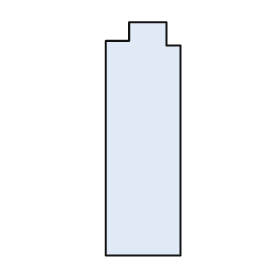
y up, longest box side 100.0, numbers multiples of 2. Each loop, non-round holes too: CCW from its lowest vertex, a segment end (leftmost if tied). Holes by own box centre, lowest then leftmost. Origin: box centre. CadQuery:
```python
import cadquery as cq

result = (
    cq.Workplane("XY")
    .moveTo(-16.0, -50.0)
    .lineTo(16.0, -50.0)
    .lineTo(16.0, 40.0)
    .lineTo(10.0, 40.0)
    .lineTo(10.0, 50.0)
    .lineTo(-6.0, 50.0)
    .lineTo(-6.0, 42.0)
    .lineTo(-16.0, 42.0)
    .close()
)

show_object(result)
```